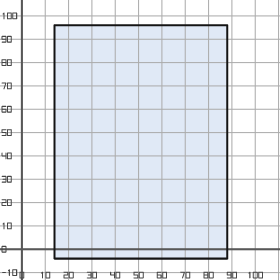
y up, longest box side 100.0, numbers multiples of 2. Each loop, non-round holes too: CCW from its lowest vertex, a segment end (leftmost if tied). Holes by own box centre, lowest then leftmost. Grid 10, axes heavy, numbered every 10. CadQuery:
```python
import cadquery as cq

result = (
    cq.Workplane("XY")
    .moveTo(14.0, -4.0)
    .lineTo(88.0, -4.0)
    .lineTo(88.0, 96.0)
    .lineTo(14.0, 96.0)
    .close()
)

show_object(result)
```